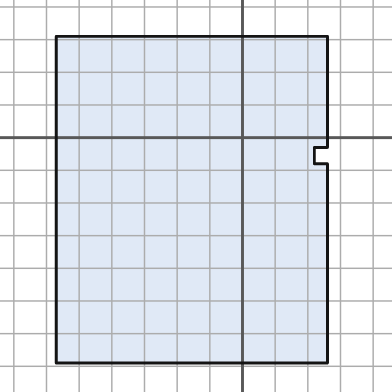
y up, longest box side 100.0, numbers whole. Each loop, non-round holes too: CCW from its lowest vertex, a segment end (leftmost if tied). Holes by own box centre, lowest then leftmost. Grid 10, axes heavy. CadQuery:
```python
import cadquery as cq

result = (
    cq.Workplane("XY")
    .moveTo(-57.0, -69.0)
    .lineTo(26.0, -69.0)
    .lineTo(26.0, -8.0)
    .lineTo(22.0, -8.0)
    .lineTo(22.0, -3.0)
    .lineTo(26.0, -3.0)
    .lineTo(26.0, 31.0)
    .lineTo(-57.0, 31.0)
    .close()
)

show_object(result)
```